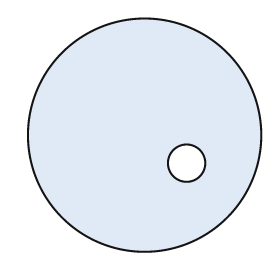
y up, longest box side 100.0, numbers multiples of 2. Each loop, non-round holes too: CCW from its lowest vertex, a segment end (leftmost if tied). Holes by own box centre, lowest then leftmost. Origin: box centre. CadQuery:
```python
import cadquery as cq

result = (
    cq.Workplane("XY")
    .moveTo(0.0, 0.0)
    .circle(50.0)
    .moveTo(18.0, -12.0)
    .circle(8.0)
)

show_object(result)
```